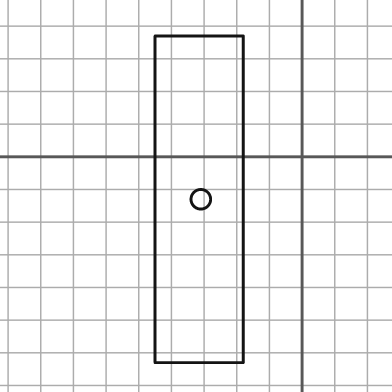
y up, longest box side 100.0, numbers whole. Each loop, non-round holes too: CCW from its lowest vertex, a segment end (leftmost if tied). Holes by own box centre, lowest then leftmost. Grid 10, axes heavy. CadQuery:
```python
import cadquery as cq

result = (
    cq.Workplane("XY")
    .moveTo(-45.0, -63.0)
    .lineTo(-18.0, -63.0)
    .lineTo(-18.0, 37.0)
    .lineTo(-45.0, 37.0)
    .close()
    .moveTo(-31.0, -13.0)
    .circle(3.0)
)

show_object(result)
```